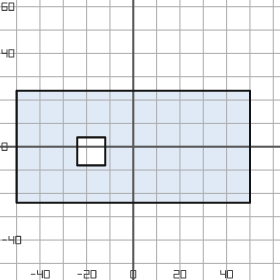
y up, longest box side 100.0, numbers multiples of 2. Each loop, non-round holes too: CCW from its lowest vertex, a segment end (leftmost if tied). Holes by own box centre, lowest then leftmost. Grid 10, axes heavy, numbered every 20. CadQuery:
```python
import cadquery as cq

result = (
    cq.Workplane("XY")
    .moveTo(-50.0, -24.0)
    .lineTo(50.0, -24.0)
    .lineTo(50.0, 24.0)
    .lineTo(-50.0, 24.0)
    .close()
    .moveTo(-24.0, -8.0)
    .lineTo(-12.0, -8.0)
    .lineTo(-12.0, 4.0)
    .lineTo(-24.0, 4.0)
    .close()
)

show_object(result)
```